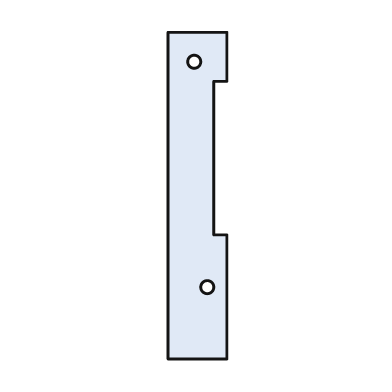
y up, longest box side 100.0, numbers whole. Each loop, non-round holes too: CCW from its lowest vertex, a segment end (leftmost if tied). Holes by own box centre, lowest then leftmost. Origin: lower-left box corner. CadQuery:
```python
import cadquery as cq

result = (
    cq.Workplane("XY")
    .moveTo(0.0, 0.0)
    .lineTo(18.0, 0.0)
    .lineTo(18.0, 38.0)
    .lineTo(14.0, 38.0)
    .lineTo(14.0, 85.0)
    .lineTo(18.0, 85.0)
    .lineTo(18.0, 100.0)
    .lineTo(0.0, 100.0)
    .close()
    .moveTo(12.0, 22.0)
    .circle(2.0)
    .moveTo(8.0, 91.0)
    .circle(2.0)
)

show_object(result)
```